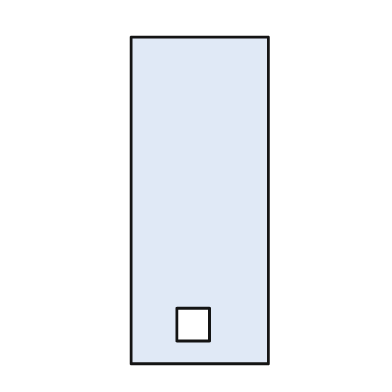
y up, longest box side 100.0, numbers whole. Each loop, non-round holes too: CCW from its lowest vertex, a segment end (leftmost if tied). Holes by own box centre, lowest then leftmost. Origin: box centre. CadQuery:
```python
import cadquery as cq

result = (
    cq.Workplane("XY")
    .moveTo(-21.0, -50.0)
    .lineTo(21.0, -50.0)
    .lineTo(21.0, 50.0)
    .lineTo(-21.0, 50.0)
    .close()
    .moveTo(-7.0, -43.0)
    .lineTo(3.0, -43.0)
    .lineTo(3.0, -33.0)
    .lineTo(-7.0, -33.0)
    .close()
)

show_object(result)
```